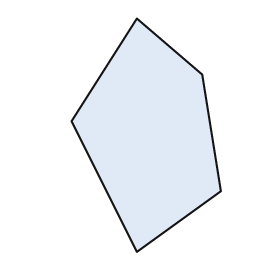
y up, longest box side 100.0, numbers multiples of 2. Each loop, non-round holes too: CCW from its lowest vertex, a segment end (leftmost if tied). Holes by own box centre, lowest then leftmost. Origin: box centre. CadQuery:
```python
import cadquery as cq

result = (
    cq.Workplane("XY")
    .moveTo(-4.0, -50.0)
    .lineTo(32.0, -24.0)
    .lineTo(24.0, 26.0)
    .lineTo(-4.0, 50.0)
    .lineTo(-32.0, 6.0)
    .close()
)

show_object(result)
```